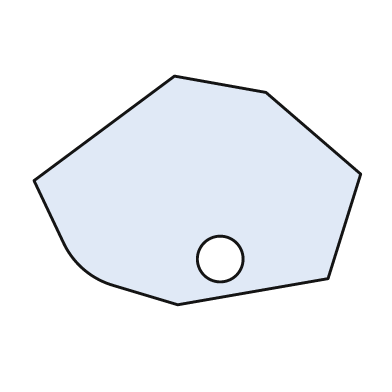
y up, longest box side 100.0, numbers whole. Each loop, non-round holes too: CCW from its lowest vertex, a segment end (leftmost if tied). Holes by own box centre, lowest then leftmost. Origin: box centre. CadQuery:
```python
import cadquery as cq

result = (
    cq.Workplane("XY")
    .moveTo(-6.0, -35.0)
    .lineTo(40.0, -27.0)
    .lineTo(50.0, 5.0)
    .lineTo(21.0, 30.0)
    .lineTo(-7.0, 35.0)
    .lineTo(-50.0, 3.0)
    .lineTo(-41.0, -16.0)
    .threePointArc((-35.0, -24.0), (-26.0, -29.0))
    .close()
    .moveTo(7.0, -21.0)
    .circle(7.0)
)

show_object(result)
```